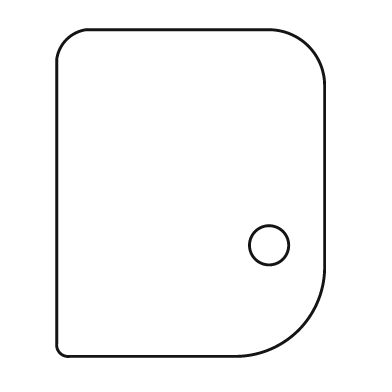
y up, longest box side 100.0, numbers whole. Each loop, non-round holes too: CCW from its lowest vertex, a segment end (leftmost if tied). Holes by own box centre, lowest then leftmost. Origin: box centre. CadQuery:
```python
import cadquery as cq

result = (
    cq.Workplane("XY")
    .moveTo(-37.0, -50.0)
    .lineTo(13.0, -50.0)
    .threePointArc((33.0, -42.0), (41.0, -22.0))
    .lineTo(41.0, 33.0)
    .threePointArc((36.0, 45.0), (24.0, 50.0))
    .lineTo(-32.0, 50.0)
    .threePointArc((-38.0, 47.0), (-41.0, 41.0))
    .lineTo(-41.0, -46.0)
    .threePointArc((-40.0, -49.0), (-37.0, -50.0))
    .close()
    .moveTo(24.0, -16.0)
    .circle(6.0)
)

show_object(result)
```